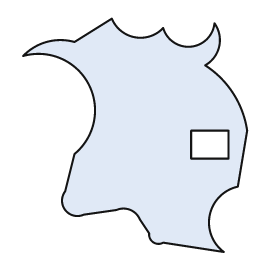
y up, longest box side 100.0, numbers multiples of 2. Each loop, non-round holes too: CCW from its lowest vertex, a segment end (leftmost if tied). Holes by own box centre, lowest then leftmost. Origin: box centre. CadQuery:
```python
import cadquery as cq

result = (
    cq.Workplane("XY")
    .moveTo(38.0, -50.0)
    .threePointArc((32.0, -34.0), (44.0, -22.0))
    .lineTo(48.0, 2.0)
    .threePointArc((42.0, 18.0), (30.0, 30.0))
    .threePointArc((36.0, 38.0), (34.0, 48.0))
    .threePointArc((24.0, 38.0), (12.0, 46.0))
    .threePointArc((0.0, 42.0), (-10.0, 50.0))
    .lineTo(-26.0, 40.0)
    .threePointArc((-38.0, 40.0), (-48.0, 34.0))
    .threePointArc((-20.0, 22.0), (-26.0, -8.0))
    .lineTo(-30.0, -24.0)
    .threePointArc((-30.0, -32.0), (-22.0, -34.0))
    .lineTo(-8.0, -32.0)
    .threePointArc((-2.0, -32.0), (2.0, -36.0))
    .lineTo(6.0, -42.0)
    .threePointArc((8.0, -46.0), (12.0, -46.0))
    .close()
    .moveTo(24.0, -10.0)
    .lineTo(40.0, -10.0)
    .lineTo(40.0, 2.0)
    .lineTo(24.0, 2.0)
    .close()
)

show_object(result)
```